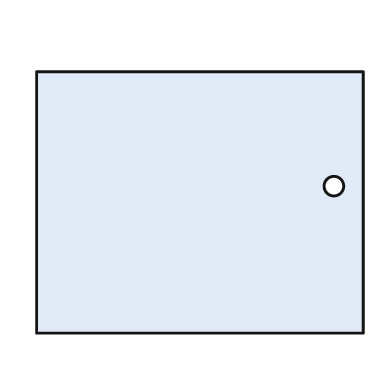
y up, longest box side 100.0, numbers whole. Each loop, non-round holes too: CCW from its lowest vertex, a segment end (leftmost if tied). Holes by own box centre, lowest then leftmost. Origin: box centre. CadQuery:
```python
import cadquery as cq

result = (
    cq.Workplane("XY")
    .moveTo(-50.0, -40.0)
    .lineTo(50.0, -40.0)
    .lineTo(50.0, 40.0)
    .lineTo(-50.0, 40.0)
    .close()
    .moveTo(41.0, 5.0)
    .circle(3.0)
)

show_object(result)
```